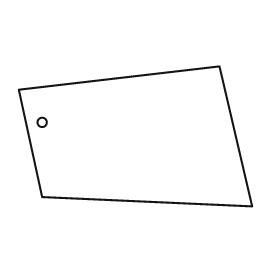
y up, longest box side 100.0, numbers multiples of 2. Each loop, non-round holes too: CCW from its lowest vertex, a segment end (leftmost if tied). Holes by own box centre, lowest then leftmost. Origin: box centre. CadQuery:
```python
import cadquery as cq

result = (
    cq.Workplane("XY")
    .moveTo(50.0, -30.0)
    .lineTo(36.0, 30.0)
    .lineTo(-50.0, 20.0)
    .lineTo(-40.0, -26.0)
    .close()
    .moveTo(-40.0, 6.0)
    .circle(2.0)
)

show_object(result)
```